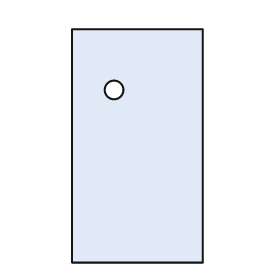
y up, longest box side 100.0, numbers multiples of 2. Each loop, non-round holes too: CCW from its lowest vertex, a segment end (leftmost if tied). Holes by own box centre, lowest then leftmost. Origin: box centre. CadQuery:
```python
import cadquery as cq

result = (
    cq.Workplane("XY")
    .moveTo(-28.0, -50.0)
    .lineTo(28.0, -50.0)
    .lineTo(28.0, 50.0)
    .lineTo(-28.0, 50.0)
    .close()
    .moveTo(-10.0, 24.0)
    .circle(4.0)
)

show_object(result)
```